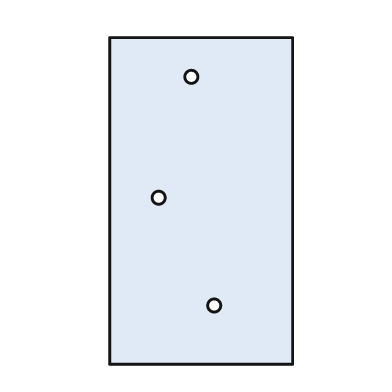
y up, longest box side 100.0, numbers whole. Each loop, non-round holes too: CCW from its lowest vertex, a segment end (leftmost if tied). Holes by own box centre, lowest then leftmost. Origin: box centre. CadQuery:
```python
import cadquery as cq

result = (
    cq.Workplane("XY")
    .moveTo(-28.0, -50.0)
    .lineTo(28.0, -50.0)
    .lineTo(28.0, 50.0)
    .lineTo(-28.0, 50.0)
    .close()
    .moveTo(4.0, -32.0)
    .circle(2.0)
    .moveTo(-13.0, 1.0)
    .circle(2.0)
    .moveTo(-3.0, 38.0)
    .circle(2.0)
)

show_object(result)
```